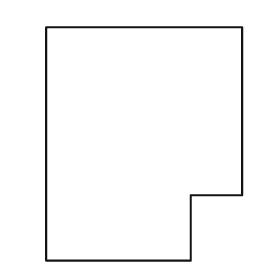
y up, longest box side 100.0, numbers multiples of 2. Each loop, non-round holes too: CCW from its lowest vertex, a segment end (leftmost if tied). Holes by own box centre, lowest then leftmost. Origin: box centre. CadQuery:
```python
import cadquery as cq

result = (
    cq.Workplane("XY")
    .moveTo(-42.0, -50.0)
    .lineTo(20.0, -50.0)
    .lineTo(20.0, -22.0)
    .lineTo(42.0, -22.0)
    .lineTo(42.0, 50.0)
    .lineTo(-42.0, 50.0)
    .close()
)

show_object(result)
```